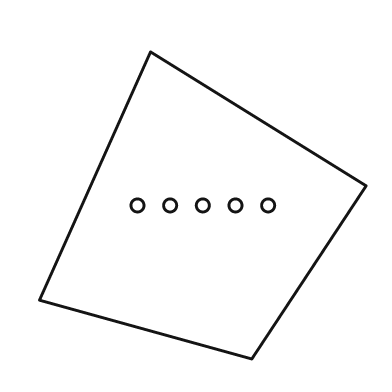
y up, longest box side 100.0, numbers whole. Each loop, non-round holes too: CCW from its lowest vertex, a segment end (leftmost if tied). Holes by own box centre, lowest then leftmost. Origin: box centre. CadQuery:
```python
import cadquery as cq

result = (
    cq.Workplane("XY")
    .moveTo(15.0, -47.0)
    .lineTo(50.0, 6.0)
    .lineTo(-16.0, 47.0)
    .lineTo(-50.0, -29.0)
    .close()
    .moveTo(-20.0, 0.0)
    .circle(2.0)
    .moveTo(-10.0, 0.0)
    .circle(2.0)
    .moveTo(0.0, 0.0)
    .circle(2.0)
    .moveTo(10.0, 0.0)
    .circle(2.0)
    .moveTo(20.0, 0.0)
    .circle(2.0)
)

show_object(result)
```